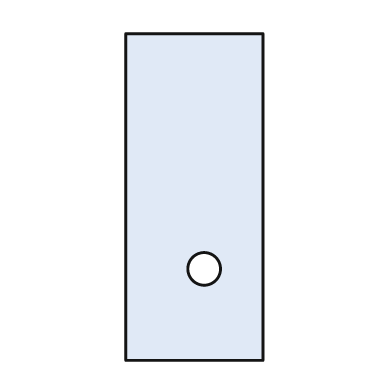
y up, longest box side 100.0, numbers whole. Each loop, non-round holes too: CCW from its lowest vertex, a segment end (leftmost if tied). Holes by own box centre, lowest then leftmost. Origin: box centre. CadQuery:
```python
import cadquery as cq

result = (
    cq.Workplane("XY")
    .moveTo(-21.0, -50.0)
    .lineTo(21.0, -50.0)
    .lineTo(21.0, 50.0)
    .lineTo(-21.0, 50.0)
    .close()
    .moveTo(3.0, -22.0)
    .circle(5.0)
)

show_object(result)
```